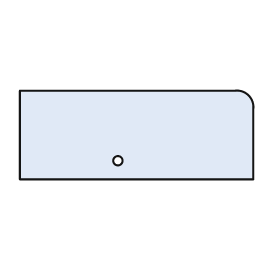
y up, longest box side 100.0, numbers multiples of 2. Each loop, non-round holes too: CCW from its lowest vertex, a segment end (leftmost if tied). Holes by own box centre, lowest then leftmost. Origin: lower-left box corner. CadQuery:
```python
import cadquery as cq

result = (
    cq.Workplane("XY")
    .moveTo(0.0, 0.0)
    .lineTo(100.0, 0.0)
    .lineTo(100.0, 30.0)
    .threePointArc((98.0, 36.0), (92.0, 38.0))
    .lineTo(0.0, 38.0)
    .close()
    .moveTo(42.0, 8.0)
    .circle(2.0)
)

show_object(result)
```